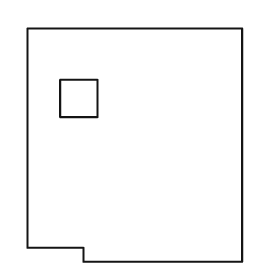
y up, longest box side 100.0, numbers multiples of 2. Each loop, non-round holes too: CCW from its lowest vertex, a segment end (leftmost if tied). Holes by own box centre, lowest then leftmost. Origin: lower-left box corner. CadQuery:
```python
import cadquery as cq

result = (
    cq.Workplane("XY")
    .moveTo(24.0, 0.0)
    .lineTo(92.0, 0.0)
    .lineTo(92.0, 100.0)
    .lineTo(0.0, 100.0)
    .lineTo(0.0, 6.0)
    .lineTo(24.0, 6.0)
    .close()
    .moveTo(14.0, 62.0)
    .lineTo(30.0, 62.0)
    .lineTo(30.0, 78.0)
    .lineTo(14.0, 78.0)
    .close()
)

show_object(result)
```